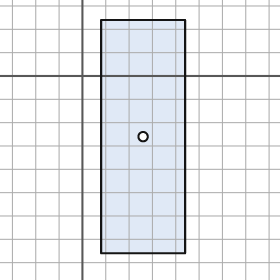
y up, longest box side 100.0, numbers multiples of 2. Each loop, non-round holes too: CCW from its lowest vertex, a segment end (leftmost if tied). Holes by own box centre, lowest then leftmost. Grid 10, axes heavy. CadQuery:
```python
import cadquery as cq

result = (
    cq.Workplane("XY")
    .moveTo(8.0, -76.0)
    .lineTo(44.0, -76.0)
    .lineTo(44.0, 24.0)
    .lineTo(8.0, 24.0)
    .close()
    .moveTo(26.0, -26.0)
    .circle(2.0)
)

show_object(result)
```